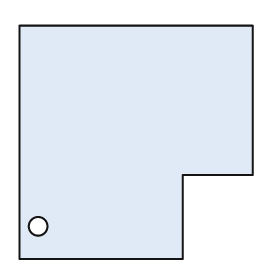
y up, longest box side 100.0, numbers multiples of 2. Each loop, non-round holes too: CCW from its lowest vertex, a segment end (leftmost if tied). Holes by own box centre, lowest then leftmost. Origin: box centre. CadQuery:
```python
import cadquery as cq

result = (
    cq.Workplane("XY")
    .moveTo(-50.0, -50.0)
    .lineTo(20.0, -50.0)
    .lineTo(20.0, -14.0)
    .lineTo(50.0, -14.0)
    .lineTo(50.0, 50.0)
    .lineTo(-50.0, 50.0)
    .close()
    .moveTo(-42.0, -36.0)
    .circle(4.0)
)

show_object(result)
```